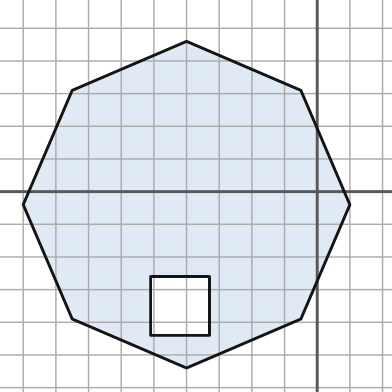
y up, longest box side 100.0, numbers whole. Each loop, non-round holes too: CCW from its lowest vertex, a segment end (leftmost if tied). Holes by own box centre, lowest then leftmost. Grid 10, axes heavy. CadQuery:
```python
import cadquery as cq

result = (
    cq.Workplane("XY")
    .moveTo(-40.0, -54.0)
    .lineTo(-5.0, -39.0)
    .lineTo(10.0, -4.0)
    .lineTo(-5.0, 31.0)
    .lineTo(-40.0, 46.0)
    .lineTo(-75.0, 31.0)
    .lineTo(-90.0, -4.0)
    .lineTo(-75.0, -39.0)
    .close()
    .moveTo(-51.0, -44.0)
    .lineTo(-33.0, -44.0)
    .lineTo(-33.0, -26.0)
    .lineTo(-51.0, -26.0)
    .close()
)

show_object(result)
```